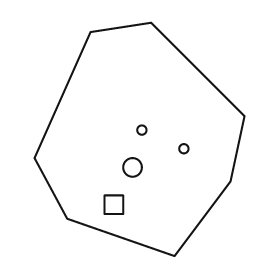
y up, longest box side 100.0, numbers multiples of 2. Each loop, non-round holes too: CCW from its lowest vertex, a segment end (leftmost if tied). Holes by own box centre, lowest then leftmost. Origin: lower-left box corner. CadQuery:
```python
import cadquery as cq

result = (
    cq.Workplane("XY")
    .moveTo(60.0, 0.0)
    .lineTo(84.0, 32.0)
    .lineTo(90.0, 60.0)
    .lineTo(50.0, 100.0)
    .lineTo(24.0, 96.0)
    .lineTo(0.0, 42.0)
    .lineTo(14.0, 16.0)
    .close()
    .moveTo(30.0, 18.0)
    .lineTo(38.0, 18.0)
    .lineTo(38.0, 26.0)
    .lineTo(30.0, 26.0)
    .close()
    .moveTo(42.0, 38.0)
    .circle(4.0)
    .moveTo(64.0, 46.0)
    .circle(2.0)
    .moveTo(46.0, 54.0)
    .circle(2.0)
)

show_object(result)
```